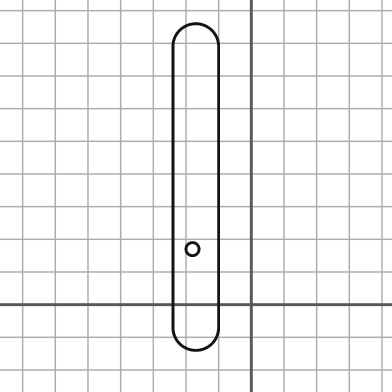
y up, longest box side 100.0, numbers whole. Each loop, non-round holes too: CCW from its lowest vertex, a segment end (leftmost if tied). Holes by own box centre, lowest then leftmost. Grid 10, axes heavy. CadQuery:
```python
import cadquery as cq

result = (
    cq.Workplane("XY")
    .moveTo(-24.0, -7.0)
    .threePointArc((-17.0, -14.0), (-10.0, -7.0))
    .lineTo(-10.0, 79.0)
    .threePointArc((-17.0, 86.0), (-24.0, 79.0))
    .close()
    .moveTo(-18.0, 17.0)
    .circle(2.0)
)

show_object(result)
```